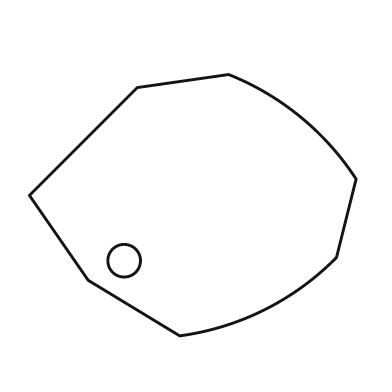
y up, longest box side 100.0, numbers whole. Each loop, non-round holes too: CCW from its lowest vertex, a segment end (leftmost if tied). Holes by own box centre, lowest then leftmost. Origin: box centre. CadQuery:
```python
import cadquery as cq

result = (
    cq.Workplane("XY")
    .moveTo(-4.0, -40.0)
    .threePointArc((22.0, -32.0), (44.0, -16.0))
    .lineTo(50.0, 8.0)
    .threePointArc((33.0, 27.0), (11.0, 40.0))
    .lineTo(-17.0, 36.0)
    .lineTo(-50.0, 3.0)
    .lineTo(-32.0, -23.0)
    .close()
    .moveTo(-21.0, -17.0)
    .circle(5.0)
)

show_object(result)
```